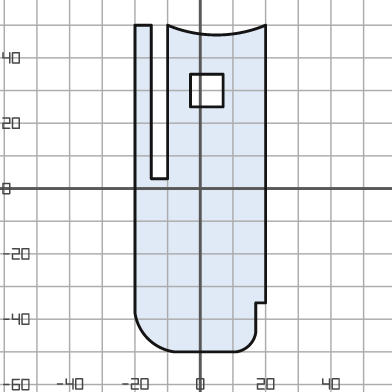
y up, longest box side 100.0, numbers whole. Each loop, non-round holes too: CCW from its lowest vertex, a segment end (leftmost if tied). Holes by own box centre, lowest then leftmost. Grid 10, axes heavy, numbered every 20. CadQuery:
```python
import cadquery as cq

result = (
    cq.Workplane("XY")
    .moveTo(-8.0, -50.0)
    .lineTo(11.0, -50.0)
    .threePointArc((15.0, -48.0), (17.0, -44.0))
    .lineTo(17.0, -35.0)
    .lineTo(20.0, -35.0)
    .lineTo(20.0, 50.0)
    .threePointArc((5.0, 47.0), (-10.0, 50.0))
    .lineTo(-10.0, 3.0)
    .lineTo(-15.0, 3.0)
    .lineTo(-15.0, 50.0)
    .lineTo(-20.0, 50.0)
    .lineTo(-20.0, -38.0)
    .threePointArc((-16.0, -46.0), (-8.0, -50.0))
    .close()
    .moveTo(-3.0, 25.0)
    .lineTo(7.0, 25.0)
    .lineTo(7.0, 35.0)
    .lineTo(-3.0, 35.0)
    .close()
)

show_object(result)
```